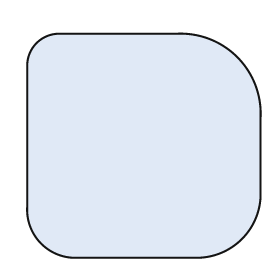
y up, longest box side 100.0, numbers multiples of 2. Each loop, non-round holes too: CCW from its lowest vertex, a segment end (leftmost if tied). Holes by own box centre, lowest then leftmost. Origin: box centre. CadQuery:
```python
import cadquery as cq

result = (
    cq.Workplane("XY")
    .moveTo(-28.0, -48.0)
    .lineTo(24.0, -48.0)
    .threePointArc((42.0, -40.0), (50.0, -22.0))
    .lineTo(50.0, 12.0)
    .threePointArc((40.0, 38.0), (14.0, 48.0))
    .lineTo(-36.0, 48.0)
    .threePointArc((-46.0, 44.0), (-50.0, 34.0))
    .lineTo(-50.0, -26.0)
    .threePointArc((-44.0, -42.0), (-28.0, -48.0))
    .close()
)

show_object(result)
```